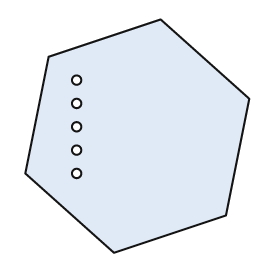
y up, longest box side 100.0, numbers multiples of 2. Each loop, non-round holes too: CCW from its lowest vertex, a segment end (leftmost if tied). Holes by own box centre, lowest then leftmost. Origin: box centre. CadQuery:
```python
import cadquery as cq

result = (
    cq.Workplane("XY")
    .moveTo(-10.0, -50.0)
    .lineTo(38.0, -34.0)
    .lineTo(48.0, 16.0)
    .lineTo(10.0, 50.0)
    .lineTo(-38.0, 34.0)
    .lineTo(-48.0, -16.0)
    .close()
    .moveTo(-26.0, -16.0)
    .circle(2.0)
    .moveTo(-26.0, -6.0)
    .circle(2.0)
    .moveTo(-26.0, 4.0)
    .circle(2.0)
    .moveTo(-26.0, 14.0)
    .circle(2.0)
    .moveTo(-26.0, 24.0)
    .circle(2.0)
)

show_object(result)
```